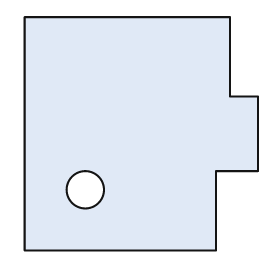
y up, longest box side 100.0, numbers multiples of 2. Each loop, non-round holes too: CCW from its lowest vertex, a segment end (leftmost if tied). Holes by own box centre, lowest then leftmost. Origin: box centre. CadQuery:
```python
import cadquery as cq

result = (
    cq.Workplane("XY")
    .moveTo(-50.0, -50.0)
    .lineTo(32.0, -50.0)
    .lineTo(32.0, -16.0)
    .lineTo(50.0, -16.0)
    .lineTo(50.0, 16.0)
    .lineTo(38.0, 16.0)
    .lineTo(38.0, 50.0)
    .lineTo(-50.0, 50.0)
    .close()
    .moveTo(-24.0, -24.0)
    .circle(8.0)
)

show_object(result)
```